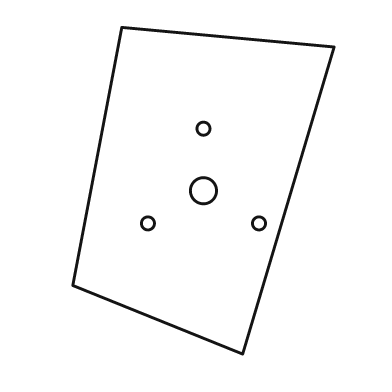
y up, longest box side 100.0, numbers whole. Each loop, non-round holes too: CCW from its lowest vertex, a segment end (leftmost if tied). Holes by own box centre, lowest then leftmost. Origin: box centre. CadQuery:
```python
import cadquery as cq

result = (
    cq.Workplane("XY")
    .moveTo(12.0, -50.0)
    .lineTo(40.0, 44.0)
    .lineTo(-25.0, 50.0)
    .lineTo(-40.0, -29.0)
    .close()
    .moveTo(-17.0, -10.0)
    .circle(2.0)
    .moveTo(17.0, -10.0)
    .circle(2.0)
    .moveTo(0.0, 0.0)
    .circle(4.0)
    .moveTo(0.0, 19.0)
    .circle(2.0)
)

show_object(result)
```